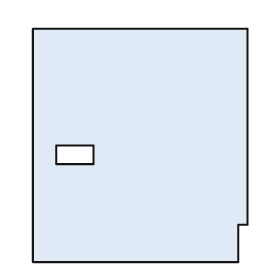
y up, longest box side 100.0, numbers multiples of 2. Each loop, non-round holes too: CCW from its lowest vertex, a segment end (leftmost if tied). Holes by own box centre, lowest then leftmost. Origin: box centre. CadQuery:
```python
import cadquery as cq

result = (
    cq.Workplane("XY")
    .moveTo(-46.0, -50.0)
    .lineTo(42.0, -50.0)
    .lineTo(42.0, -34.0)
    .lineTo(46.0, -34.0)
    .lineTo(46.0, 50.0)
    .lineTo(-46.0, 50.0)
    .close()
    .moveTo(-36.0, -8.0)
    .lineTo(-20.0, -8.0)
    .lineTo(-20.0, 0.0)
    .lineTo(-36.0, 0.0)
    .close()
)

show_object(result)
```